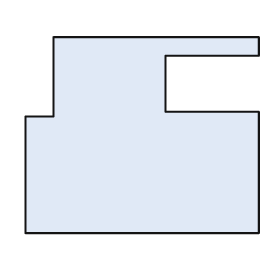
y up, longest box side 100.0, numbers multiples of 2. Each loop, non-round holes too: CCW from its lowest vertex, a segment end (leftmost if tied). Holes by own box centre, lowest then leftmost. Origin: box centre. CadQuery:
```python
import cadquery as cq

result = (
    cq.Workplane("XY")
    .moveTo(-50.0, -42.0)
    .lineTo(50.0, -42.0)
    .lineTo(50.0, 10.0)
    .lineTo(10.0, 10.0)
    .lineTo(10.0, 34.0)
    .lineTo(50.0, 34.0)
    .lineTo(50.0, 42.0)
    .lineTo(-38.0, 42.0)
    .lineTo(-38.0, 8.0)
    .lineTo(-50.0, 8.0)
    .close()
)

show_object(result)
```